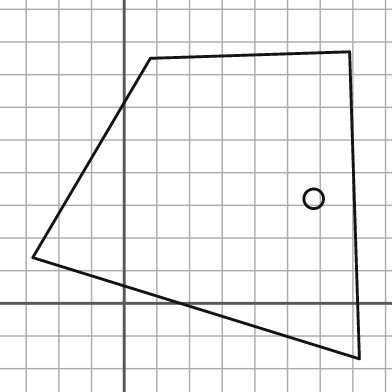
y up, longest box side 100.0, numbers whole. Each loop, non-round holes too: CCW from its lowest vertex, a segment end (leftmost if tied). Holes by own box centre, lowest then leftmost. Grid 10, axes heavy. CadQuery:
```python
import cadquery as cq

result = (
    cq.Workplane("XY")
    .moveTo(72.0, -17.0)
    .lineTo(69.0, 77.0)
    .lineTo(8.0, 75.0)
    .lineTo(-28.0, 14.0)
    .close()
    .moveTo(58.0, 32.0)
    .circle(3.0)
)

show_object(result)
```